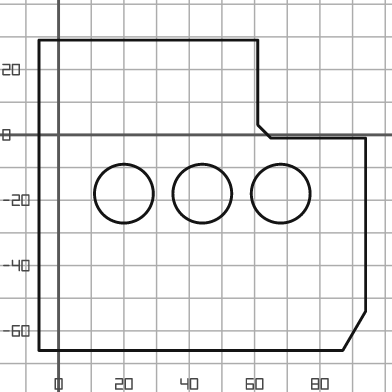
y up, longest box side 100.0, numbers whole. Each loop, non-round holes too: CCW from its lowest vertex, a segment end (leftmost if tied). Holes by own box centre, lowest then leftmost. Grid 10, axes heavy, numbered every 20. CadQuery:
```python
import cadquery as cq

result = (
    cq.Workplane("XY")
    .moveTo(-6.0, -66.0)
    .lineTo(87.0, -66.0)
    .lineTo(94.0, -54.0)
    .lineTo(94.0, -1.0)
    .lineTo(65.0, -1.0)
    .lineTo(61.0, 3.0)
    .lineTo(61.0, 29.0)
    .lineTo(-6.0, 29.0)
    .close()
    .moveTo(20.0, -18.0)
    .circle(9.0)
    .moveTo(44.0, -18.0)
    .circle(9.0)
    .moveTo(68.0, -18.0)
    .circle(9.0)
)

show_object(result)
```